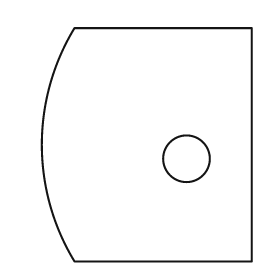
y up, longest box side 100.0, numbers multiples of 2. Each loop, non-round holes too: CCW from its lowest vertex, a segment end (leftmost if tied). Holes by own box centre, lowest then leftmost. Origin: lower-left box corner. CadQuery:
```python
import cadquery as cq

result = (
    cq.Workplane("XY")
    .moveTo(14.0, 0.0)
    .lineTo(90.0, 0.0)
    .lineTo(90.0, 100.0)
    .lineTo(14.0, 100.0)
    .threePointArc((0.0, 50.0), (14.0, 0.0))
    .close()
    .moveTo(62.0, 44.0)
    .circle(10.0)
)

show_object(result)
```